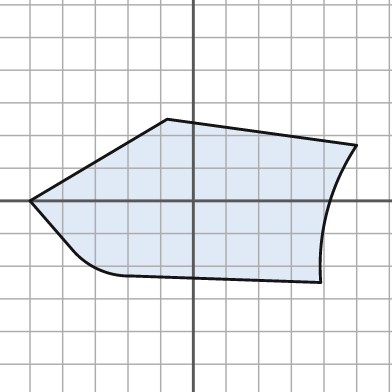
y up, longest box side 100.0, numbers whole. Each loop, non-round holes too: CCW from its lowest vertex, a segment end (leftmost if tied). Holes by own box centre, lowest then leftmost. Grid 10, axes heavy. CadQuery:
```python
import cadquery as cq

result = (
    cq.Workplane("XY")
    .moveTo(39.0, -25.0)
    .threePointArc((41.0, -3.0), (50.0, 17.0))
    .lineTo(-8.0, 25.0)
    .lineTo(-50.0, 0.0)
    .lineTo(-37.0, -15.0)
    .threePointArc((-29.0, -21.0), (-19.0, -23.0))
    .close()
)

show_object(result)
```